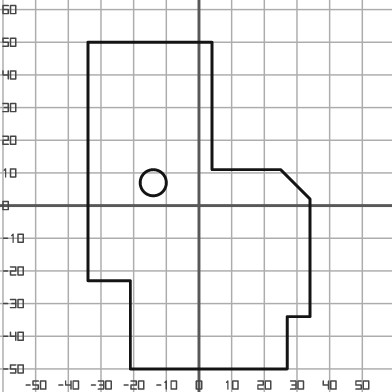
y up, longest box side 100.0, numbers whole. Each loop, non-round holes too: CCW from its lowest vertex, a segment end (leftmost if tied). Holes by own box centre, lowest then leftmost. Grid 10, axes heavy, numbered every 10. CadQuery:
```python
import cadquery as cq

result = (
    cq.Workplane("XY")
    .moveTo(-21.0, -50.0)
    .lineTo(27.0, -50.0)
    .lineTo(27.0, -34.0)
    .lineTo(34.0, -34.0)
    .lineTo(34.0, 2.0)
    .lineTo(25.0, 11.0)
    .lineTo(4.0, 11.0)
    .lineTo(4.0, 50.0)
    .lineTo(-34.0, 50.0)
    .lineTo(-34.0, -23.0)
    .lineTo(-21.0, -23.0)
    .close()
    .moveTo(-14.0, 7.0)
    .circle(4.0)
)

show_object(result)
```